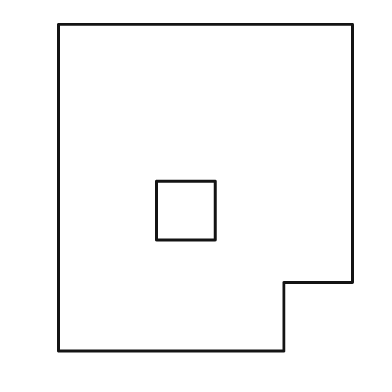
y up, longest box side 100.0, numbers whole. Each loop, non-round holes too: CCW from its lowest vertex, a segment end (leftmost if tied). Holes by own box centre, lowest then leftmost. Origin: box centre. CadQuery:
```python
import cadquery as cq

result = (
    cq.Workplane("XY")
    .moveTo(-45.0, -50.0)
    .lineTo(24.0, -50.0)
    .lineTo(24.0, -29.0)
    .lineTo(45.0, -29.0)
    .lineTo(45.0, 50.0)
    .lineTo(-45.0, 50.0)
    .close()
    .moveTo(-15.0, -16.0)
    .lineTo(3.0, -16.0)
    .lineTo(3.0, 2.0)
    .lineTo(-15.0, 2.0)
    .close()
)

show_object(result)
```